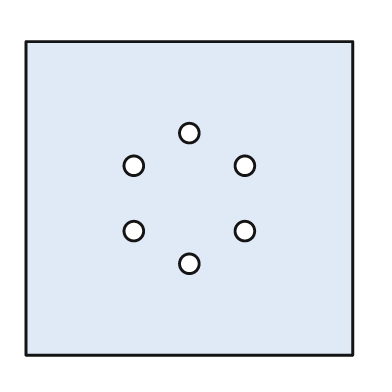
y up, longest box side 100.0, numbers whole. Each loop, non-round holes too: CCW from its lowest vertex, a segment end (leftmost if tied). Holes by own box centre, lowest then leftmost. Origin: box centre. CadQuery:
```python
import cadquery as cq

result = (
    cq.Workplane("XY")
    .moveTo(-50.0, -48.0)
    .lineTo(50.0, -48.0)
    .lineTo(50.0, 48.0)
    .lineTo(-50.0, 48.0)
    .close()
    .moveTo(0.0, -20.0)
    .circle(3.0)
    .moveTo(-17.0, -10.0)
    .circle(3.0)
    .moveTo(17.0, -10.0)
    .circle(3.0)
    .moveTo(-17.0, 10.0)
    .circle(3.0)
    .moveTo(17.0, 10.0)
    .circle(3.0)
    .moveTo(0.0, 20.0)
    .circle(3.0)
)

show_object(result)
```